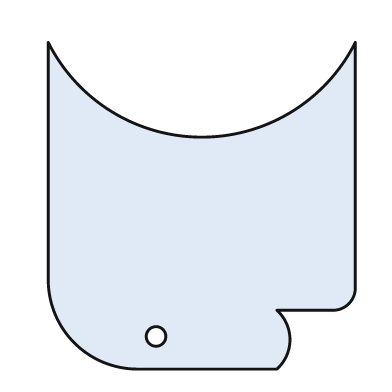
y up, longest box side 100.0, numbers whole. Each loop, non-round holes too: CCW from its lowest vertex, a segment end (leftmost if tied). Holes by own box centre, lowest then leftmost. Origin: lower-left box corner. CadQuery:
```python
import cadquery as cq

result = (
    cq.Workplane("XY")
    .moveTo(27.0, 0.0)
    .lineTo(70.0, 0.0)
    .threePointArc((74.0, 9.0), (70.0, 18.0))
    .lineTo(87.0, 18.0)
    .threePointArc((92.0, 20.0), (94.0, 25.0))
    .lineTo(94.0, 100.0)
    .threePointArc((47.0, 71.0), (0.0, 100.0))
    .lineTo(0.0, 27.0)
    .threePointArc((8.0, 8.0), (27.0, 0.0))
    .close()
    .moveTo(33.0, 10.0)
    .circle(3.0)
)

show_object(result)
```